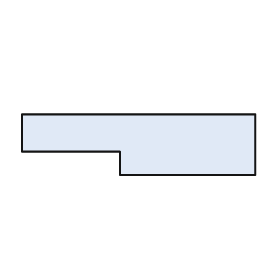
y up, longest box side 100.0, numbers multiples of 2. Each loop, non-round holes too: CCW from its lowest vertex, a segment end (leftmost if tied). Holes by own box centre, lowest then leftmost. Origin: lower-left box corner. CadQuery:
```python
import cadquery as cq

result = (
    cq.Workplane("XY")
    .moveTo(42.0, 0.0)
    .lineTo(100.0, 0.0)
    .lineTo(100.0, 26.0)
    .lineTo(0.0, 26.0)
    .lineTo(0.0, 10.0)
    .lineTo(42.0, 10.0)
    .close()
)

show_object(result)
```